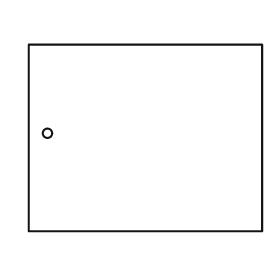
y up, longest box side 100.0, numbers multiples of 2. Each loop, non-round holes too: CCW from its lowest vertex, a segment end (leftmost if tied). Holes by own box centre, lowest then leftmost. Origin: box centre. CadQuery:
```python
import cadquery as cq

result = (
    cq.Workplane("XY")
    .moveTo(-50.0, -40.0)
    .lineTo(50.0, -40.0)
    .lineTo(50.0, 40.0)
    .lineTo(-50.0, 40.0)
    .close()
    .moveTo(-42.0, 2.0)
    .circle(2.0)
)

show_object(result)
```